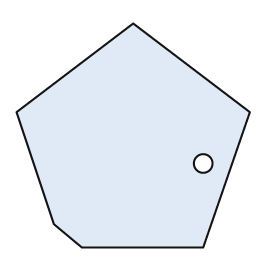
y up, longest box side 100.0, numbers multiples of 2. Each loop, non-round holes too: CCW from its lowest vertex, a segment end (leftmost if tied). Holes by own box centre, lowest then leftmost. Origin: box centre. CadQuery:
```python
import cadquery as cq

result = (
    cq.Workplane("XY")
    .moveTo(-22.0, -48.0)
    .lineTo(30.0, -48.0)
    .lineTo(50.0, 10.0)
    .lineTo(0.0, 48.0)
    .lineTo(-50.0, 10.0)
    .lineTo(-34.0, -38.0)
    .close()
    .moveTo(30.0, -12.0)
    .circle(4.0)
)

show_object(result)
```